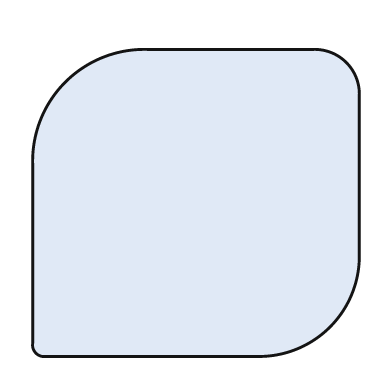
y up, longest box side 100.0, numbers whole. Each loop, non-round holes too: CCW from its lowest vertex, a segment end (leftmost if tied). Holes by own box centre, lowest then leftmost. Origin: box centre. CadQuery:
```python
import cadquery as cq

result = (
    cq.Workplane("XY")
    .moveTo(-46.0, -47.0)
    .lineTo(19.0, -47.0)
    .threePointArc((41.0, -38.0), (50.0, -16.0))
    .lineTo(50.0, 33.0)
    .threePointArc((46.0, 43.0), (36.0, 47.0))
    .lineTo(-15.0, 47.0)
    .threePointArc((-40.0, 37.0), (-50.0, 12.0))
    .lineTo(-50.0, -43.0)
    .threePointArc((-49.0, -46.0), (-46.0, -47.0))
    .close()
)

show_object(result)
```